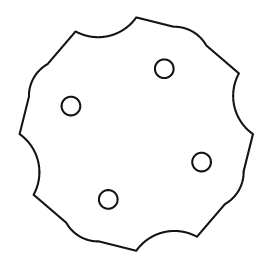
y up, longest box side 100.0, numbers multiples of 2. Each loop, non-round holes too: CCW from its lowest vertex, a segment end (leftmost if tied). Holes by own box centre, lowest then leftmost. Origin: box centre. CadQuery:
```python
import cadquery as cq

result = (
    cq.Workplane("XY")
    .moveTo(0.0, -50.0)
    .threePointArc((12.0, -42.0), (26.0, -44.0))
    .lineTo(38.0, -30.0)
    .threePointArc((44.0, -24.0), (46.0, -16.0))
    .lineTo(50.0, 0.0)
    .threePointArc((42.0, 12.0), (44.0, 26.0))
    .lineTo(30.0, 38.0)
    .threePointArc((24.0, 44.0), (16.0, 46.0))
    .lineTo(0.0, 50.0)
    .threePointArc((-12.0, 42.0), (-26.0, 44.0))
    .lineTo(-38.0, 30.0)
    .threePointArc((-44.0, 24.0), (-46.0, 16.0))
    .lineTo(-50.0, 0.0)
    .threePointArc((-42.0, -12.0), (-44.0, -26.0))
    .lineTo(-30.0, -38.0)
    .threePointArc((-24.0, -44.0), (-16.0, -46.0))
    .close()
    .moveTo(-12.0, -28.0)
    .circle(4.0)
    .moveTo(28.0, -12.0)
    .circle(4.0)
    .moveTo(-28.0, 12.0)
    .circle(4.0)
    .moveTo(12.0, 28.0)
    .circle(4.0)
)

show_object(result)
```